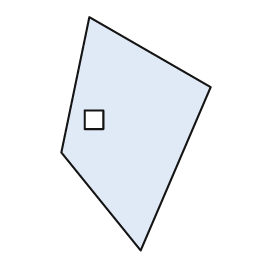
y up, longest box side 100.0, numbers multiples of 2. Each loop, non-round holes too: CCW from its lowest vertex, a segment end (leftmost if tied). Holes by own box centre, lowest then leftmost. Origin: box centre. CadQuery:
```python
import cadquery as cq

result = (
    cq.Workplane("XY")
    .moveTo(2.0, -50.0)
    .lineTo(32.0, 20.0)
    .lineTo(-20.0, 50.0)
    .lineTo(-32.0, -8.0)
    .close()
    .moveTo(-22.0, 2.0)
    .lineTo(-14.0, 2.0)
    .lineTo(-14.0, 10.0)
    .lineTo(-22.0, 10.0)
    .close()
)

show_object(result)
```